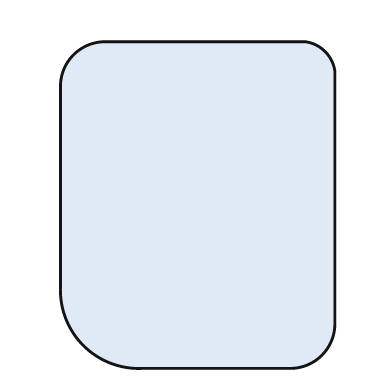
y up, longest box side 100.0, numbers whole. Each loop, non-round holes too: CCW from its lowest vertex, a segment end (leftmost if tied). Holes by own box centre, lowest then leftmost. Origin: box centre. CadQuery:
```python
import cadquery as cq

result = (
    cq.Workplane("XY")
    .moveTo(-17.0, -50.0)
    .lineTo(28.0, -50.0)
    .threePointArc((38.0, -46.0), (42.0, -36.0))
    .lineTo(42.0, 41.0)
    .threePointArc((39.0, 47.0), (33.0, 50.0))
    .lineTo(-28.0, 50.0)
    .threePointArc((-38.0, 46.0), (-42.0, 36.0))
    .lineTo(-42.0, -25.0)
    .threePointArc((-35.0, -43.0), (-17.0, -50.0))
    .close()
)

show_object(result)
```